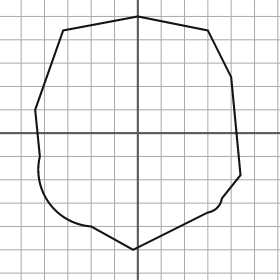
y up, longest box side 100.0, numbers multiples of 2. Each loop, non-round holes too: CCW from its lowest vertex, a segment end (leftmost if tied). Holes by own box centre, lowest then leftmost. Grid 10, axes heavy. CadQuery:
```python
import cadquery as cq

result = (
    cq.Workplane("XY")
    .moveTo(-2.0, -50.0)
    .lineTo(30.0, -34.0)
    .threePointArc((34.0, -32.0), (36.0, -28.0))
    .lineTo(44.0, -18.0)
    .lineTo(40.0, 24.0)
    .lineTo(30.0, 44.0)
    .lineTo(0.0, 50.0)
    .lineTo(-32.0, 44.0)
    .lineTo(-44.0, 10.0)
    .lineTo(-42.0, -10.0)
    .threePointArc((-38.0, -30.0), (-20.0, -40.0))
    .close()
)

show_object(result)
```